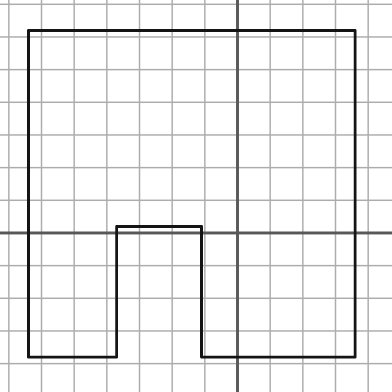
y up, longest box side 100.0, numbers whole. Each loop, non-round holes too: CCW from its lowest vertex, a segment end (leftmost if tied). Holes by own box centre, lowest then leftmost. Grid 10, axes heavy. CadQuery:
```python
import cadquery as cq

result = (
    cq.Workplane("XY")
    .moveTo(-64.0, -38.0)
    .lineTo(-37.0, -38.0)
    .lineTo(-37.0, 2.0)
    .lineTo(-11.0, 2.0)
    .lineTo(-11.0, -38.0)
    .lineTo(36.0, -38.0)
    .lineTo(36.0, 62.0)
    .lineTo(-64.0, 62.0)
    .close()
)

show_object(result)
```